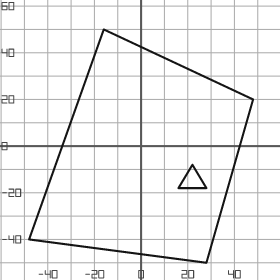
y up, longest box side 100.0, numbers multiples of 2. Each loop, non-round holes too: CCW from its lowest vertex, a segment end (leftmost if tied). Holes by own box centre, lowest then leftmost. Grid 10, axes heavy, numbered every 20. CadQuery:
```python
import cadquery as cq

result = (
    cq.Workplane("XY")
    .moveTo(28.0, -50.0)
    .lineTo(48.0, 20.0)
    .lineTo(-16.0, 50.0)
    .lineTo(-48.0, -40.0)
    .close()
    .moveTo(16.0, -18.0)
    .lineTo(28.0, -18.0)
    .lineTo(22.0, -8.0)
    .close()
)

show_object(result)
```